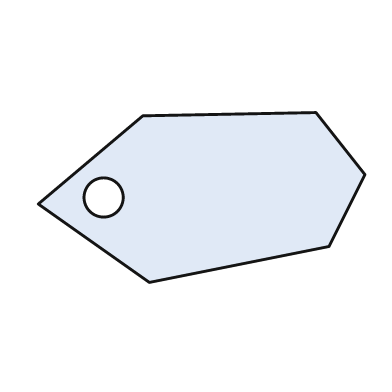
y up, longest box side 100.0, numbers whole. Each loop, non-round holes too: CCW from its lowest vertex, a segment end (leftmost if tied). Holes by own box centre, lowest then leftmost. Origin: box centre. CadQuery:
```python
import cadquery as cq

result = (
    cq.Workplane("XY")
    .moveTo(-16.0, -26.0)
    .lineTo(39.0, -15.0)
    .lineTo(50.0, 7.0)
    .lineTo(35.0, 26.0)
    .lineTo(-18.0, 25.0)
    .lineTo(-50.0, -2.0)
    .close()
    .moveTo(-30.0, 0.0)
    .circle(6.0)
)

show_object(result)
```